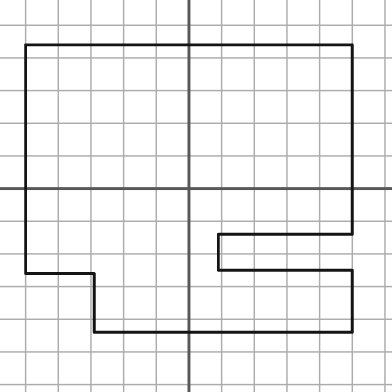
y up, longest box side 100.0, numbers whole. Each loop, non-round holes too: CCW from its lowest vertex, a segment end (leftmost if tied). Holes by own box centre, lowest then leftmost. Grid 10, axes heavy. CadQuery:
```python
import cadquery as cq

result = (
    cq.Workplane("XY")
    .moveTo(-29.0, -44.0)
    .lineTo(50.0, -44.0)
    .lineTo(50.0, -25.0)
    .lineTo(9.0, -25.0)
    .lineTo(9.0, -14.0)
    .lineTo(50.0, -14.0)
    .lineTo(50.0, 44.0)
    .lineTo(-50.0, 44.0)
    .lineTo(-50.0, -26.0)
    .lineTo(-29.0, -26.0)
    .close()
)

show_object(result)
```